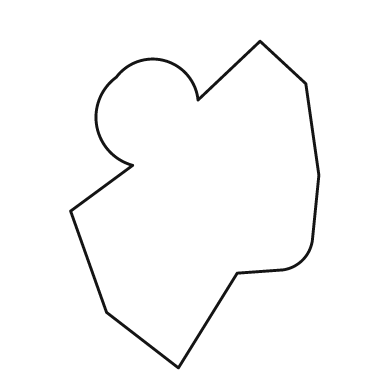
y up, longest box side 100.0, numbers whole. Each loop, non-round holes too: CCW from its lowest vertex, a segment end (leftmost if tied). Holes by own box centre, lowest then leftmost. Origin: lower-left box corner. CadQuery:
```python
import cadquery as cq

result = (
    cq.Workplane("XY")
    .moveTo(33.0, 0.0)
    .lineTo(51.0, 29.0)
    .lineTo(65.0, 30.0)
    .threePointArc((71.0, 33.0), (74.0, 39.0))
    .lineTo(76.0, 59.0)
    .lineTo(72.0, 87.0)
    .lineTo(58.0, 100.0)
    .lineTo(39.0, 82.0)
    .threePointArc((29.0, 94.0), (14.0, 89.0))
    .threePointArc((8.0, 74.0), (19.0, 62.0))
    .lineTo(0.0, 48.0)
    .lineTo(11.0, 17.0)
    .close()
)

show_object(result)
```